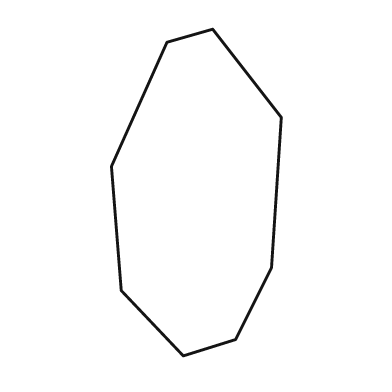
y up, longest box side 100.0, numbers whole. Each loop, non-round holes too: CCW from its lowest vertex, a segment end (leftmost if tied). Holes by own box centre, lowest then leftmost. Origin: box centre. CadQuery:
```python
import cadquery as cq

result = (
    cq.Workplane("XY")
    .moveTo(-4.0, -50.0)
    .lineTo(12.0, -45.0)
    .lineTo(23.0, -23.0)
    .lineTo(26.0, 23.0)
    .lineTo(5.0, 50.0)
    .lineTo(-9.0, 46.0)
    .lineTo(-26.0, 8.0)
    .lineTo(-23.0, -30.0)
    .close()
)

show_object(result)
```